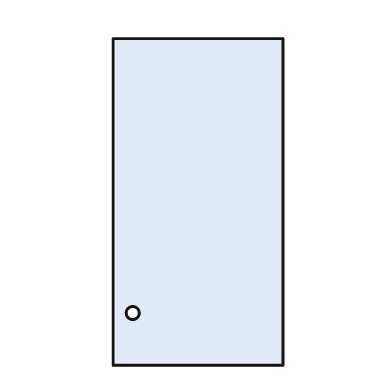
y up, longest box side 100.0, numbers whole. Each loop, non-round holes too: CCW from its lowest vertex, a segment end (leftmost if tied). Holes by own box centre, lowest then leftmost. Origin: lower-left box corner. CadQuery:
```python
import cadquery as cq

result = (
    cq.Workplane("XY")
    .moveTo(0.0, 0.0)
    .lineTo(52.0, 0.0)
    .lineTo(52.0, 100.0)
    .lineTo(0.0, 100.0)
    .close()
    .moveTo(6.0, 16.0)
    .circle(2.0)
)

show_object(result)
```